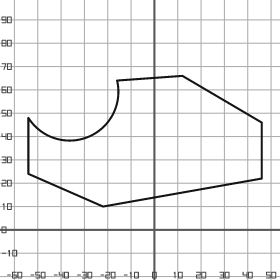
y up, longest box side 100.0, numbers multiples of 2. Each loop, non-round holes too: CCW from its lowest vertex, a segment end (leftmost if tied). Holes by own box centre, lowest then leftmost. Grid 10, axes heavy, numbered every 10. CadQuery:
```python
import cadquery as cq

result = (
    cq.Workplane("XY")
    .moveTo(-22.0, 10.0)
    .lineTo(46.0, 22.0)
    .lineTo(46.0, 46.0)
    .lineTo(12.0, 66.0)
    .lineTo(-16.0, 64.0)
    .threePointArc((-28.0, 40.0), (-54.0, 48.0))
    .lineTo(-54.0, 24.0)
    .close()
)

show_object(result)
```